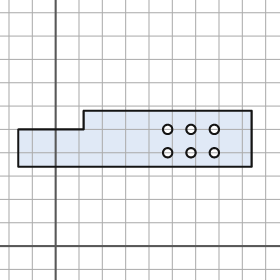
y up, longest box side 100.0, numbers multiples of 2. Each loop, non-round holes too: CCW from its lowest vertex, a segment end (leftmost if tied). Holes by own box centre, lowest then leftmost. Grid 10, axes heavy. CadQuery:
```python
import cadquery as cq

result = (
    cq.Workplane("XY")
    .moveTo(-16.0, 34.0)
    .lineTo(84.0, 34.0)
    .lineTo(84.0, 58.0)
    .lineTo(12.0, 58.0)
    .lineTo(12.0, 50.0)
    .lineTo(-16.0, 50.0)
    .close()
    .moveTo(48.0, 40.0)
    .circle(2.0)
    .moveTo(58.0, 40.0)
    .circle(2.0)
    .moveTo(68.0, 40.0)
    .circle(2.0)
    .moveTo(48.0, 50.0)
    .circle(2.0)
    .moveTo(58.0, 50.0)
    .circle(2.0)
    .moveTo(68.0, 50.0)
    .circle(2.0)
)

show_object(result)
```